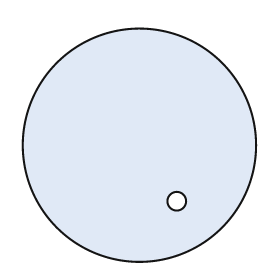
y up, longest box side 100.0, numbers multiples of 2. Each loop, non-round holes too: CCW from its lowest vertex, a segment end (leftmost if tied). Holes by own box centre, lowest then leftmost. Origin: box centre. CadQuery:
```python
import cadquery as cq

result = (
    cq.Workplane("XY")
    .moveTo(0.0, 0.0)
    .circle(50.0)
    .moveTo(16.0, -24.0)
    .circle(4.0)
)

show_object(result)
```